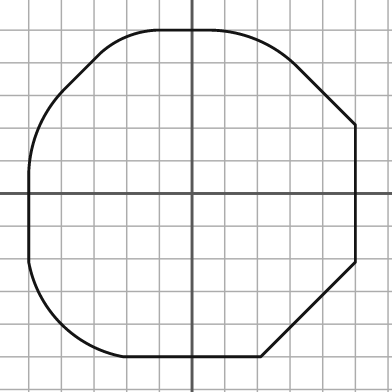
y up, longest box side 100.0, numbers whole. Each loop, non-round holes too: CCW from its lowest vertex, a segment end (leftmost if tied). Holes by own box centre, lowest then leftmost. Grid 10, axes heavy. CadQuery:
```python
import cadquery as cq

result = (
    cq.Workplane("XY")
    .moveTo(-21.0, -50.0)
    .lineTo(21.0, -50.0)
    .lineTo(50.0, -21.0)
    .lineTo(50.0, 21.0)
    .lineTo(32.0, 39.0)
    .threePointArc((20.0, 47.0), (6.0, 50.0))
    .lineTo(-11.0, 50.0)
    .threePointArc((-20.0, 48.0), (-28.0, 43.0))
    .lineTo(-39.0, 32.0)
    .threePointArc((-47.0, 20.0), (-50.0, 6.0))
    .lineTo(-50.0, -21.0)
    .threePointArc((-40.0, -40.0), (-21.0, -50.0))
    .close()
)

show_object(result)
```